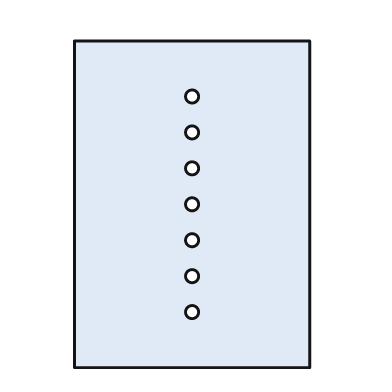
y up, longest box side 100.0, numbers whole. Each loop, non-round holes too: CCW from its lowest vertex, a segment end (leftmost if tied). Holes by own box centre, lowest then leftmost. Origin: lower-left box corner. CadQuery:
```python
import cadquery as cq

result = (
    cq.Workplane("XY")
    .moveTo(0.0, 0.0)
    .lineTo(72.0, 0.0)
    .lineTo(72.0, 100.0)
    .lineTo(0.0, 100.0)
    .close()
    .moveTo(36.0, 17.0)
    .circle(2.0)
    .moveTo(36.0, 28.0)
    .circle(2.0)
    .moveTo(36.0, 39.0)
    .circle(2.0)
    .moveTo(36.0, 50.0)
    .circle(2.0)
    .moveTo(36.0, 61.0)
    .circle(2.0)
    .moveTo(36.0, 72.0)
    .circle(2.0)
    .moveTo(36.0, 83.0)
    .circle(2.0)
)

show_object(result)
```